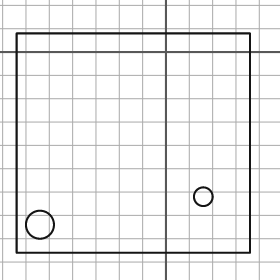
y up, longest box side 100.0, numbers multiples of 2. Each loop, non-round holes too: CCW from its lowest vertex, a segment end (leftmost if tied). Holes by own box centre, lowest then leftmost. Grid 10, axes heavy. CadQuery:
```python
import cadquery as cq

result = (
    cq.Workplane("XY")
    .moveTo(-64.0, -86.0)
    .lineTo(36.0, -86.0)
    .lineTo(36.0, 8.0)
    .lineTo(-64.0, 8.0)
    .close()
    .moveTo(-54.0, -74.0)
    .circle(6.0)
    .moveTo(16.0, -62.0)
    .circle(4.0)
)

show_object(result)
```